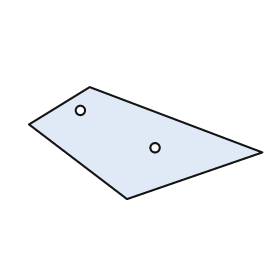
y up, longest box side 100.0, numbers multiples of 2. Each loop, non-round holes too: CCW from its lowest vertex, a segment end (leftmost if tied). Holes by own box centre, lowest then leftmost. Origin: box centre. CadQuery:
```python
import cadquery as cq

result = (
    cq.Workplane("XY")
    .moveTo(-8.0, -24.0)
    .lineTo(50.0, -4.0)
    .lineTo(-24.0, 24.0)
    .lineTo(-50.0, 8.0)
    .close()
    .moveTo(4.0, -2.0)
    .circle(2.0)
    .moveTo(-28.0, 14.0)
    .circle(2.0)
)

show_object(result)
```